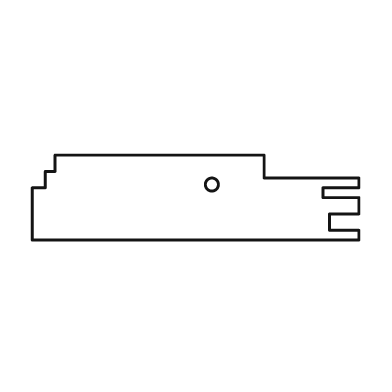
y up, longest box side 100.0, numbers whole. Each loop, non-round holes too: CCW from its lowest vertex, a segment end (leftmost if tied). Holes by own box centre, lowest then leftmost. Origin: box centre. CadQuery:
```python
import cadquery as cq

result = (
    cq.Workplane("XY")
    .moveTo(-50.0, -13.0)
    .lineTo(50.0, -13.0)
    .lineTo(50.0, -10.0)
    .lineTo(41.0, -10.0)
    .lineTo(41.0, -5.0)
    .lineTo(50.0, -5.0)
    .lineTo(50.0, 0.0)
    .lineTo(39.0, 0.0)
    .lineTo(39.0, 3.0)
    .lineTo(50.0, 3.0)
    .lineTo(50.0, 6.0)
    .lineTo(21.0, 6.0)
    .lineTo(21.0, 13.0)
    .lineTo(-43.0, 13.0)
    .lineTo(-43.0, 8.0)
    .lineTo(-46.0, 8.0)
    .lineTo(-46.0, 3.0)
    .lineTo(-50.0, 3.0)
    .close()
    .moveTo(5.0, 4.0)
    .circle(2.0)
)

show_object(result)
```